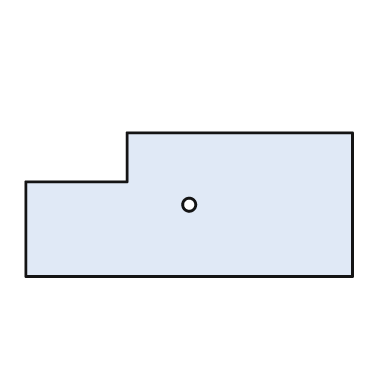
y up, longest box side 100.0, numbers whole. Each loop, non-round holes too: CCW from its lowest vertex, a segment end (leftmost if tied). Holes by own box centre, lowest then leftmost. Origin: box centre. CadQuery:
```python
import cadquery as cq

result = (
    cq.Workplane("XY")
    .moveTo(-50.0, -22.0)
    .lineTo(50.0, -22.0)
    .lineTo(50.0, 22.0)
    .lineTo(-19.0, 22.0)
    .lineTo(-19.0, 7.0)
    .lineTo(-50.0, 7.0)
    .close()
    .moveTo(0.0, 0.0)
    .circle(2.0)
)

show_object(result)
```